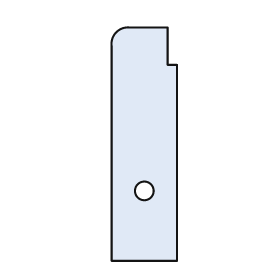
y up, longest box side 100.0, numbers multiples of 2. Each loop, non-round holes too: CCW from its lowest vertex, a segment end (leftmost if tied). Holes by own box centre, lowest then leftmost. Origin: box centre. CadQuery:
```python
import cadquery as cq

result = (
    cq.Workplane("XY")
    .moveTo(-14.0, -50.0)
    .lineTo(14.0, -50.0)
    .lineTo(14.0, 34.0)
    .lineTo(10.0, 34.0)
    .lineTo(10.0, 50.0)
    .lineTo(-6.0, 50.0)
    .threePointArc((-12.0, 48.0), (-14.0, 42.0))
    .close()
    .moveTo(0.0, -20.0)
    .circle(4.0)
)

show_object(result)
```